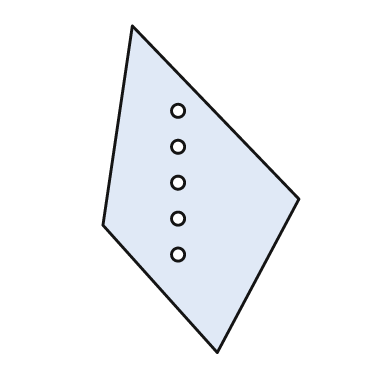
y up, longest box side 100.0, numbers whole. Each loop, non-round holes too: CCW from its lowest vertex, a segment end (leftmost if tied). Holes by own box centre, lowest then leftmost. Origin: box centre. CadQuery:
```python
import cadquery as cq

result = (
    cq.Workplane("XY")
    .moveTo(5.0, -50.0)
    .lineTo(30.0, -3.0)
    .lineTo(-21.0, 50.0)
    .lineTo(-30.0, -11.0)
    .close()
    .moveTo(-7.0, -20.0)
    .circle(2.0)
    .moveTo(-7.0, -9.0)
    .circle(2.0)
    .moveTo(-7.0, 2.0)
    .circle(2.0)
    .moveTo(-7.0, 13.0)
    .circle(2.0)
    .moveTo(-7.0, 24.0)
    .circle(2.0)
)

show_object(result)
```